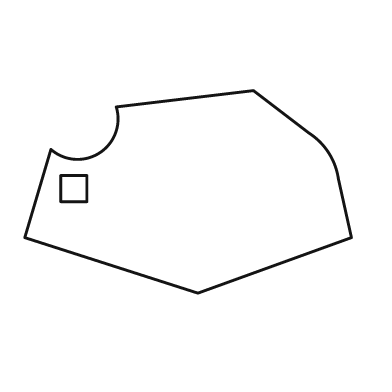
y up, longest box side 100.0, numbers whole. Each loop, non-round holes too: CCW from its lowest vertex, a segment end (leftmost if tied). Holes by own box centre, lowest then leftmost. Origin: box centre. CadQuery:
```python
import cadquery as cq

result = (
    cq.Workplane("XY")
    .moveTo(3.0, -31.0)
    .lineTo(50.0, -14.0)
    .lineTo(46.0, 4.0)
    .threePointArc((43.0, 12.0), (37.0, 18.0))
    .lineTo(20.0, 31.0)
    .lineTo(-22.0, 26.0)
    .threePointArc((-27.0, 12.0), (-42.0, 13.0))
    .lineTo(-50.0, -14.0)
    .close()
    .moveTo(-39.0, -3.0)
    .lineTo(-31.0, -3.0)
    .lineTo(-31.0, 5.0)
    .lineTo(-39.0, 5.0)
    .close()
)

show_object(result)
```